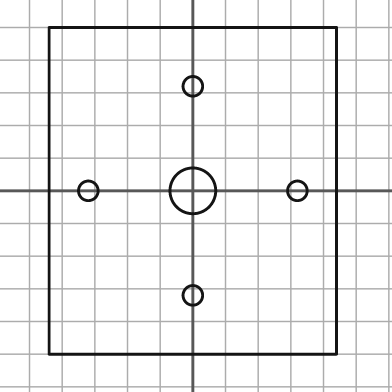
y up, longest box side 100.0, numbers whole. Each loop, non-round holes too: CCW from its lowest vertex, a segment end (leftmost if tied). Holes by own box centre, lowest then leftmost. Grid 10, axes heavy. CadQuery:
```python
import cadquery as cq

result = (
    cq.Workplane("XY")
    .moveTo(-44.0, -50.0)
    .lineTo(44.0, -50.0)
    .lineTo(44.0, 50.0)
    .lineTo(-44.0, 50.0)
    .close()
    .moveTo(0.0, -32.0)
    .circle(3.0)
    .moveTo(-32.0, 0.0)
    .circle(3.0)
    .moveTo(0.0, 0.0)
    .circle(7.0)
    .moveTo(32.0, 0.0)
    .circle(3.0)
    .moveTo(0.0, 32.0)
    .circle(3.0)
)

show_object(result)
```